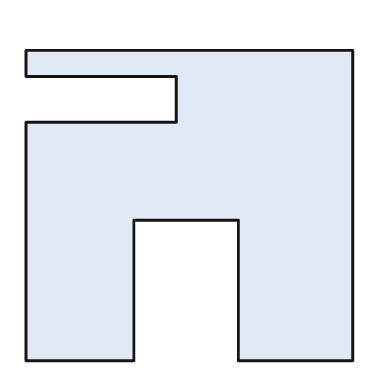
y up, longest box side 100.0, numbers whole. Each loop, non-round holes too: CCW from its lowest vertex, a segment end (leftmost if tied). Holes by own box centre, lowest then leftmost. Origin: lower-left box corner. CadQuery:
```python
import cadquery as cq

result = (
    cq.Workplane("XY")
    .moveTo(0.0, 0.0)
    .lineTo(33.0, 0.0)
    .lineTo(33.0, 43.0)
    .lineTo(65.0, 43.0)
    .lineTo(65.0, 0.0)
    .lineTo(100.0, 0.0)
    .lineTo(100.0, 95.0)
    .lineTo(0.0, 95.0)
    .lineTo(0.0, 87.0)
    .lineTo(46.0, 87.0)
    .lineTo(46.0, 73.0)
    .lineTo(0.0, 73.0)
    .close()
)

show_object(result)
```